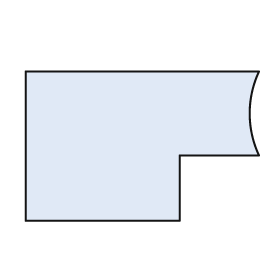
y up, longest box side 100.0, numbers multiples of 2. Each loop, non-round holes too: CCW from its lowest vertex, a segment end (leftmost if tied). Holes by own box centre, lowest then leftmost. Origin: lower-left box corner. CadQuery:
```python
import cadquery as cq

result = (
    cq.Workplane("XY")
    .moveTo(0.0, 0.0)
    .lineTo(66.0, 0.0)
    .lineTo(66.0, 28.0)
    .lineTo(100.0, 28.0)
    .threePointArc((96.0, 46.0), (100.0, 64.0))
    .lineTo(0.0, 64.0)
    .close()
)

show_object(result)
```